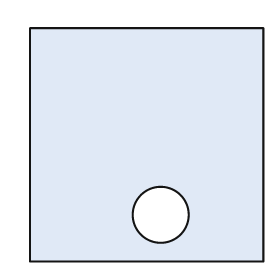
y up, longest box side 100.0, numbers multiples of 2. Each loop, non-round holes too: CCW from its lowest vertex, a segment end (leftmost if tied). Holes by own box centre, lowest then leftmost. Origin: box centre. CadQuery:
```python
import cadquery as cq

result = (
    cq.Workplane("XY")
    .moveTo(-50.0, -50.0)
    .lineTo(50.0, -50.0)
    .lineTo(50.0, 50.0)
    .lineTo(-50.0, 50.0)
    .close()
    .moveTo(6.0, -30.0)
    .circle(12.0)
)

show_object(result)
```